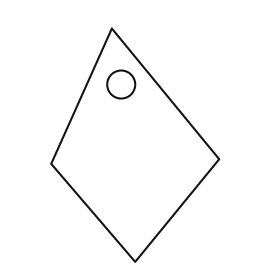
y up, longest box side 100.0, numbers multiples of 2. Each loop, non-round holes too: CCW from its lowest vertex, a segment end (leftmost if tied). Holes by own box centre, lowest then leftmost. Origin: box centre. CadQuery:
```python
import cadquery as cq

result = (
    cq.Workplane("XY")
    .moveTo(0.0, -50.0)
    .lineTo(36.0, -6.0)
    .lineTo(-10.0, 50.0)
    .lineTo(-36.0, -8.0)
    .close()
    .moveTo(-6.0, 26.0)
    .circle(6.0)
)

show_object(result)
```